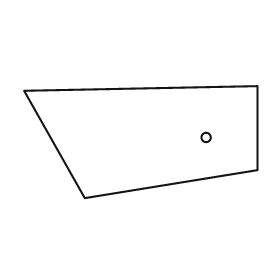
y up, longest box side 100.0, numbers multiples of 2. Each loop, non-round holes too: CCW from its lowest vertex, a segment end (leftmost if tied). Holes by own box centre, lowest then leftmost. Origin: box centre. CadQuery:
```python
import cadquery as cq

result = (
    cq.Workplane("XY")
    .moveTo(-24.0, -24.0)
    .lineTo(50.0, -12.0)
    .lineTo(50.0, 24.0)
    .lineTo(-50.0, 22.0)
    .close()
    .moveTo(28.0, 2.0)
    .circle(2.0)
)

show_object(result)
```